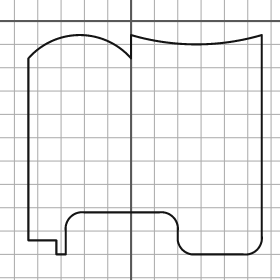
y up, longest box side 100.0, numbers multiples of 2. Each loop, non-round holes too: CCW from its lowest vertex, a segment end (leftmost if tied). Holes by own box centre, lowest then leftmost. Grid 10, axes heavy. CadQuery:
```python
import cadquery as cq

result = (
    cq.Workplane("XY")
    .moveTo(-32.0, -100.0)
    .lineTo(-28.0, -100.0)
    .lineTo(-28.0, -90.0)
    .threePointArc((-26.0, -84.0), (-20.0, -82.0))
    .lineTo(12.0, -82.0)
    .threePointArc((18.0, -84.0), (20.0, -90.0))
    .lineTo(20.0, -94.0)
    .threePointArc((22.0, -98.0), (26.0, -100.0))
    .lineTo(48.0, -100.0)
    .threePointArc((54.0, -98.0), (56.0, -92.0))
    .lineTo(56.0, -6.0)
    .threePointArc((28.0, -10.0), (0.0, -6.0))
    .lineTo(0.0, -16.0)
    .threePointArc((-22.0, -6.0), (-44.0, -16.0))
    .lineTo(-44.0, -94.0)
    .lineTo(-32.0, -94.0)
    .close()
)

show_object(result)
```